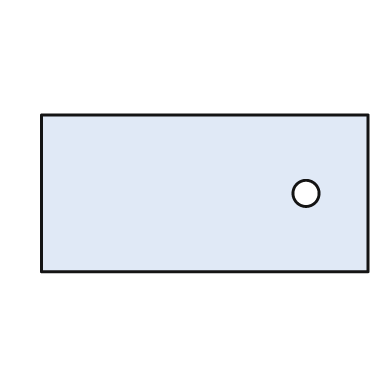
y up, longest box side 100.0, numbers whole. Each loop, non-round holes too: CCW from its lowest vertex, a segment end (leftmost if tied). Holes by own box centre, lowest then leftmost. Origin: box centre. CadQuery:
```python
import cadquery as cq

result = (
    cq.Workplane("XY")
    .moveTo(-50.0, -24.0)
    .lineTo(50.0, -24.0)
    .lineTo(50.0, 24.0)
    .lineTo(-50.0, 24.0)
    .close()
    .moveTo(31.0, 0.0)
    .circle(4.0)
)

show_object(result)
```